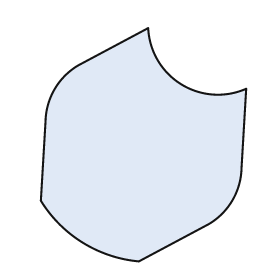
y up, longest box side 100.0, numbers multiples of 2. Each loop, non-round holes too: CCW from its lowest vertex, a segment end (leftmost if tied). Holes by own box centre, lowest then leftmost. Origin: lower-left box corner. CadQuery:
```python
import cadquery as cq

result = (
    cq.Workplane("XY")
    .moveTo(42.0, 0.0)
    .lineTo(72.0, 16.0)
    .threePointArc((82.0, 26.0), (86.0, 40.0))
    .lineTo(88.0, 74.0)
    .threePointArc((60.0, 76.0), (46.0, 100.0))
    .lineTo(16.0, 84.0)
    .threePointArc((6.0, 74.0), (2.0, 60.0))
    .lineTo(0.0, 26.0)
    .threePointArc((18.0, 8.0), (42.0, 0.0))
    .close()
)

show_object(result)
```